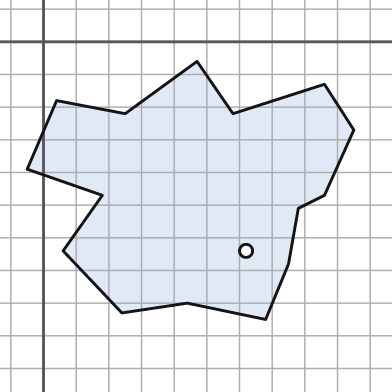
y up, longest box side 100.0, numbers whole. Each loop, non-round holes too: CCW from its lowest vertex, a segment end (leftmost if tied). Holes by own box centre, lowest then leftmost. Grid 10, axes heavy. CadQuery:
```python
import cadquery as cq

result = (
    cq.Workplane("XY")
    .moveTo(68.0, -85.0)
    .lineTo(75.0, -68.0)
    .lineTo(78.0, -51.0)
    .lineTo(86.0, -47.0)
    .lineTo(95.0, -27.0)
    .lineTo(86.0, -13.0)
    .lineTo(58.0, -22.0)
    .lineTo(47.0, -6.0)
    .lineTo(25.0, -22.0)
    .lineTo(4.0, -18.0)
    .lineTo(-5.0, -39.0)
    .lineTo(18.0, -47.0)
    .lineTo(6.0, -64.0)
    .lineTo(24.0, -83.0)
    .lineTo(44.0, -80.0)
    .close()
    .moveTo(62.0, -64.0)
    .circle(2.0)
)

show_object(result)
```